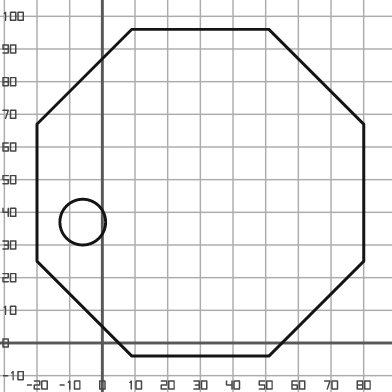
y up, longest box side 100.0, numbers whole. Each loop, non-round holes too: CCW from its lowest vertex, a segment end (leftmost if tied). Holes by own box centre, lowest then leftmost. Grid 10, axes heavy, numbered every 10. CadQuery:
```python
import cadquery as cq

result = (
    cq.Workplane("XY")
    .moveTo(9.0, -4.0)
    .lineTo(51.0, -4.0)
    .lineTo(80.0, 25.0)
    .lineTo(80.0, 67.0)
    .lineTo(51.0, 96.0)
    .lineTo(9.0, 96.0)
    .lineTo(-20.0, 67.0)
    .lineTo(-20.0, 25.0)
    .close()
    .moveTo(-6.0, 37.0)
    .circle(7.0)
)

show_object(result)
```